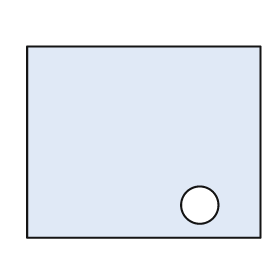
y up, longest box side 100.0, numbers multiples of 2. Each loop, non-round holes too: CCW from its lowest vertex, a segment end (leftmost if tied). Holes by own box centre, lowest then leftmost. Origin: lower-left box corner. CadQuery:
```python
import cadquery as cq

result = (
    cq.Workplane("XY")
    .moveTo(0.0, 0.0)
    .lineTo(100.0, 0.0)
    .lineTo(100.0, 82.0)
    .lineTo(0.0, 82.0)
    .close()
    .moveTo(74.0, 14.0)
    .circle(8.0)
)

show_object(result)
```